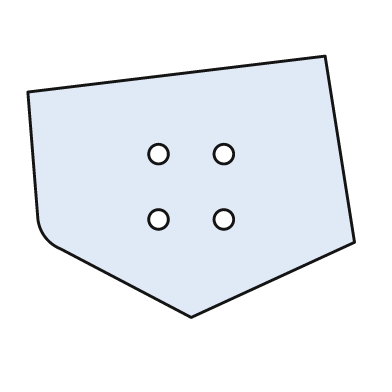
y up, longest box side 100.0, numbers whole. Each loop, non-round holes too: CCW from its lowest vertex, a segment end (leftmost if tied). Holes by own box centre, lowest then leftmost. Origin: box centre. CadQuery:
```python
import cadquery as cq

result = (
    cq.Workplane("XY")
    .moveTo(0.0, -40.0)
    .lineTo(50.0, -17.0)
    .lineTo(41.0, 40.0)
    .lineTo(-50.0, 29.0)
    .lineTo(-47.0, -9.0)
    .threePointArc((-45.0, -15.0), (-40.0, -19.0))
    .close()
    .moveTo(-10.0, -10.0)
    .circle(3.0)
    .moveTo(10.0, -10.0)
    .circle(3.0)
    .moveTo(-10.0, 10.0)
    .circle(3.0)
    .moveTo(10.0, 10.0)
    .circle(3.0)
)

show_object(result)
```